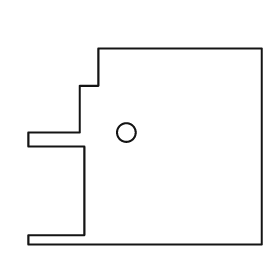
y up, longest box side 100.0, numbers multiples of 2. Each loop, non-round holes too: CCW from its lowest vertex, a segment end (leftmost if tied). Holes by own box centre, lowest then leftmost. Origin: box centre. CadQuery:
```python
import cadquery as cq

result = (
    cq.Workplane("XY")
    .moveTo(-50.0, -42.0)
    .lineTo(50.0, -42.0)
    .lineTo(50.0, 42.0)
    .lineTo(-20.0, 42.0)
    .lineTo(-20.0, 26.0)
    .lineTo(-28.0, 26.0)
    .lineTo(-28.0, 6.0)
    .lineTo(-50.0, 6.0)
    .lineTo(-50.0, 0.0)
    .lineTo(-26.0, 0.0)
    .lineTo(-26.0, -38.0)
    .lineTo(-50.0, -38.0)
    .close()
    .moveTo(-8.0, 6.0)
    .circle(4.0)
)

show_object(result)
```